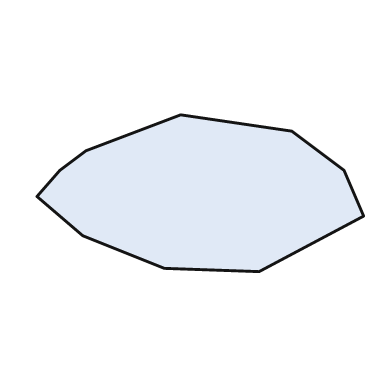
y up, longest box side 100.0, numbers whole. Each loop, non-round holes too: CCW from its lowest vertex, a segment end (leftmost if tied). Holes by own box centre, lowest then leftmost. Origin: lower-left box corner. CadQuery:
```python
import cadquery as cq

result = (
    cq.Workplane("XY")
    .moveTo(68.0, 0.0)
    .lineTo(100.0, 17.0)
    .lineTo(94.0, 31.0)
    .lineTo(78.0, 43.0)
    .lineTo(44.0, 48.0)
    .lineTo(15.0, 37.0)
    .lineTo(7.0, 31.0)
    .lineTo(0.0, 23.0)
    .lineTo(14.0, 11.0)
    .lineTo(39.0, 1.0)
    .close()
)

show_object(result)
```